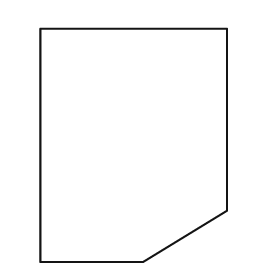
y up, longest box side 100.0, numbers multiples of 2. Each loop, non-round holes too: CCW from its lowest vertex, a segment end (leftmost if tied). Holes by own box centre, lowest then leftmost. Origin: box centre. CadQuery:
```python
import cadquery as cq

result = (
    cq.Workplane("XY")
    .moveTo(-40.0, -50.0)
    .lineTo(4.0, -50.0)
    .lineTo(40.0, -28.0)
    .lineTo(40.0, 50.0)
    .lineTo(-40.0, 50.0)
    .close()
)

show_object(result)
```